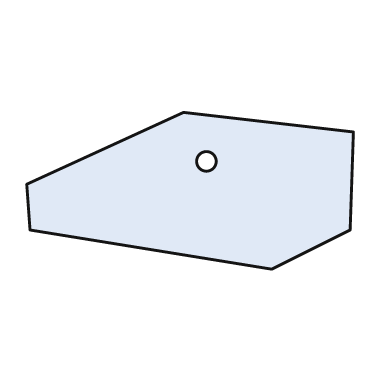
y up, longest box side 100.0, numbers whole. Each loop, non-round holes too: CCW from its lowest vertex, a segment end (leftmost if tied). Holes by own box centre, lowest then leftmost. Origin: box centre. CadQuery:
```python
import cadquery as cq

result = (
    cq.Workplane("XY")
    .moveTo(25.0, -24.0)
    .lineTo(49.0, -12.0)
    .lineTo(50.0, 18.0)
    .lineTo(-2.0, 24.0)
    .lineTo(-50.0, 2.0)
    .lineTo(-49.0, -12.0)
    .close()
    .moveTo(5.0, 9.0)
    .circle(3.0)
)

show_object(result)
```